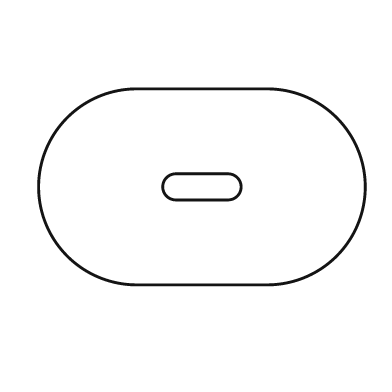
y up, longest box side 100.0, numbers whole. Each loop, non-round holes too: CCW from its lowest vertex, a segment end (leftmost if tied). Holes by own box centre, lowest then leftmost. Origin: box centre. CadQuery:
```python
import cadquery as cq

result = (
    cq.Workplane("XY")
    .moveTo(-20.0, -30.0)
    .lineTo(20.0, -30.0)
    .threePointArc((50.0, 0.0), (20.0, 30.0))
    .lineTo(-20.0, 30.0)
    .threePointArc((-50.0, 0.0), (-20.0, -30.0))
    .close()
    .moveTo(-8.0, -4.0)
    .lineTo(8.0, -4.0)
    .threePointArc((12.0, 0.0), (8.0, 4.0))
    .lineTo(-8.0, 4.0)
    .threePointArc((-12.0, 0.0), (-8.0, -4.0))
    .close()
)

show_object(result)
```